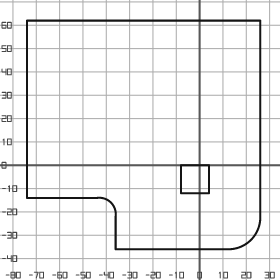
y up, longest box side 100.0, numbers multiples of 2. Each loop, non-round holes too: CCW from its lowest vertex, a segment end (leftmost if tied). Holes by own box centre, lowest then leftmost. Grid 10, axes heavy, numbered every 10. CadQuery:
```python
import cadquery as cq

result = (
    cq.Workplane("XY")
    .moveTo(-36.0, -36.0)
    .lineTo(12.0, -36.0)
    .threePointArc((22.0, -32.0), (26.0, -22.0))
    .lineTo(26.0, 62.0)
    .lineTo(-74.0, 62.0)
    .lineTo(-74.0, -14.0)
    .lineTo(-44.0, -14.0)
    .threePointArc((-38.0, -16.0), (-36.0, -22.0))
    .close()
    .moveTo(-8.0, -12.0)
    .lineTo(4.0, -12.0)
    .lineTo(4.0, 0.0)
    .lineTo(-8.0, 0.0)
    .close()
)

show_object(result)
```